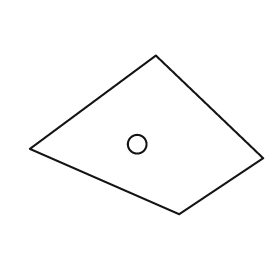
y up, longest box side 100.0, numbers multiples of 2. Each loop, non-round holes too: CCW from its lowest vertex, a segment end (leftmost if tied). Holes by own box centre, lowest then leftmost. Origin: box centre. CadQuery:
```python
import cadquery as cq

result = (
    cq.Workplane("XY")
    .moveTo(14.0, -34.0)
    .lineTo(50.0, -10.0)
    .lineTo(4.0, 34.0)
    .lineTo(-50.0, -6.0)
    .close()
    .moveTo(-4.0, -4.0)
    .circle(4.0)
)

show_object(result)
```